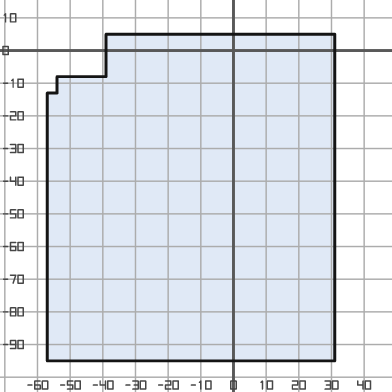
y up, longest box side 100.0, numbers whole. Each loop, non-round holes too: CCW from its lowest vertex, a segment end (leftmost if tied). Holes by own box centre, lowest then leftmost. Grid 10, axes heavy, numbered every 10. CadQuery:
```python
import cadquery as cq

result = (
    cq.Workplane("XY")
    .moveTo(-57.0, -95.0)
    .lineTo(31.0, -95.0)
    .lineTo(31.0, 5.0)
    .lineTo(-39.0, 5.0)
    .lineTo(-39.0, -8.0)
    .lineTo(-54.0, -8.0)
    .lineTo(-54.0, -13.0)
    .lineTo(-57.0, -13.0)
    .close()
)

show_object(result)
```